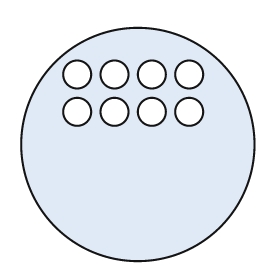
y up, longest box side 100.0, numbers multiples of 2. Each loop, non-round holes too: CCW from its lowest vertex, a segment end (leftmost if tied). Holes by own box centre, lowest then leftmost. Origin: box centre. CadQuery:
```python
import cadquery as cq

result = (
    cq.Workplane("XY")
    .moveTo(0.0, 0.0)
    .circle(50.0)
    .moveTo(-26.0, 14.0)
    .circle(6.0)
    .moveTo(-10.0, 14.0)
    .circle(6.0)
    .moveTo(6.0, 14.0)
    .circle(6.0)
    .moveTo(22.0, 14.0)
    .circle(6.0)
    .moveTo(-26.0, 30.0)
    .circle(6.0)
    .moveTo(-10.0, 30.0)
    .circle(6.0)
    .moveTo(6.0, 30.0)
    .circle(6.0)
    .moveTo(22.0, 30.0)
    .circle(6.0)
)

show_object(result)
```